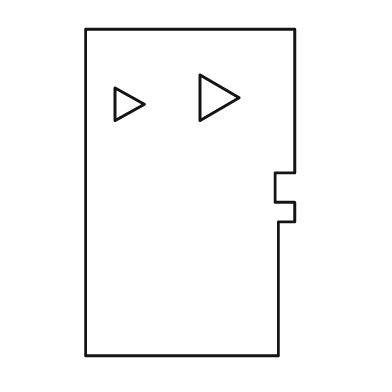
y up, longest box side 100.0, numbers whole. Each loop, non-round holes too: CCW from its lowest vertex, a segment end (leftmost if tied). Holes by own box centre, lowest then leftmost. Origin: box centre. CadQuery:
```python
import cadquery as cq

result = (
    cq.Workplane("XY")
    .moveTo(-32.0, -50.0)
    .lineTo(27.0, -50.0)
    .lineTo(27.0, -9.0)
    .lineTo(32.0, -9.0)
    .lineTo(32.0, -3.0)
    .lineTo(26.0, -3.0)
    .lineTo(26.0, 6.0)
    .lineTo(32.0, 6.0)
    .lineTo(32.0, 50.0)
    .lineTo(-32.0, 50.0)
    .close()
    .moveTo(-23.0, 22.0)
    .lineTo(-14.0, 27.0)
    .lineTo(-23.0, 32.0)
    .close()
    .moveTo(3.0, 22.0)
    .lineTo(15.0, 29.0)
    .lineTo(3.0, 36.0)
    .close()
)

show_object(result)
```